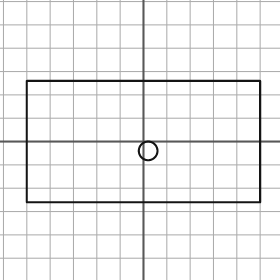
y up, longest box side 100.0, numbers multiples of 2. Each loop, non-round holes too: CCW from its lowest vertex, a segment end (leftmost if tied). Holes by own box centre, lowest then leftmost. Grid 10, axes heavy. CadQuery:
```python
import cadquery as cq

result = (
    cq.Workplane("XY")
    .moveTo(-50.0, -26.0)
    .lineTo(50.0, -26.0)
    .lineTo(50.0, 26.0)
    .lineTo(-50.0, 26.0)
    .close()
    .moveTo(2.0, -4.0)
    .circle(4.0)
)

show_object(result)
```